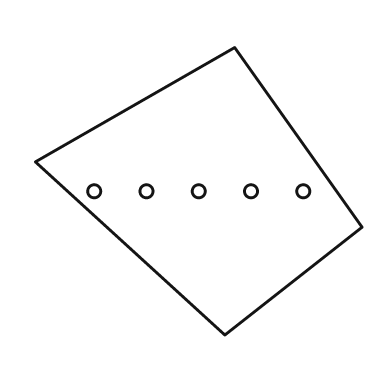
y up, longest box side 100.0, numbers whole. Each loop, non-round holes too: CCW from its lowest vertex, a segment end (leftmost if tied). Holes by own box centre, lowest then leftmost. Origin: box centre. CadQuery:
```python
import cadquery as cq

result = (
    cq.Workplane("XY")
    .moveTo(8.0, -44.0)
    .lineTo(50.0, -11.0)
    .lineTo(11.0, 44.0)
    .lineTo(-50.0, 9.0)
    .close()
    .moveTo(-32.0, 0.0)
    .circle(2.0)
    .moveTo(-16.0, 0.0)
    .circle(2.0)
    .moveTo(0.0, 0.0)
    .circle(2.0)
    .moveTo(16.0, 0.0)
    .circle(2.0)
    .moveTo(32.0, 0.0)
    .circle(2.0)
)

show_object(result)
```